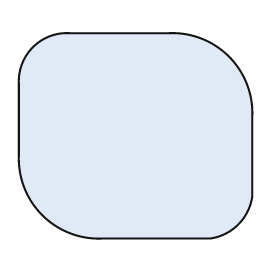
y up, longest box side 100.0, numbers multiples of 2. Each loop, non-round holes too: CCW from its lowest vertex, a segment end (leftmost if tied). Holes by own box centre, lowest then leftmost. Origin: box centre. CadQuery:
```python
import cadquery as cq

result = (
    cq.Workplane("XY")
    .moveTo(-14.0, -44.0)
    .lineTo(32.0, -44.0)
    .threePointArc((44.0, -38.0), (50.0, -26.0))
    .lineTo(50.0, 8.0)
    .threePointArc((40.0, 34.0), (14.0, 44.0))
    .lineTo(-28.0, 44.0)
    .threePointArc((-44.0, 38.0), (-50.0, 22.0))
    .lineTo(-50.0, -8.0)
    .threePointArc((-40.0, -34.0), (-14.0, -44.0))
    .close()
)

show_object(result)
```